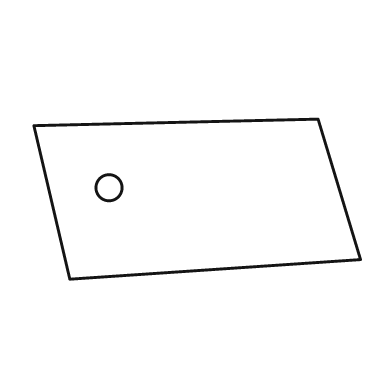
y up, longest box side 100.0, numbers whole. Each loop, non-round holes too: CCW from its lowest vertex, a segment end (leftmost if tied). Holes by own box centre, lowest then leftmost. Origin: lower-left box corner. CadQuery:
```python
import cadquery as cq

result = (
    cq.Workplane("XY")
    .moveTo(11.0, 0.0)
    .lineTo(100.0, 6.0)
    .lineTo(87.0, 49.0)
    .lineTo(0.0, 47.0)
    .close()
    .moveTo(23.0, 28.0)
    .circle(4.0)
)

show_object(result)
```